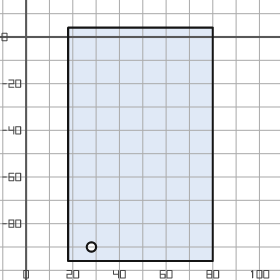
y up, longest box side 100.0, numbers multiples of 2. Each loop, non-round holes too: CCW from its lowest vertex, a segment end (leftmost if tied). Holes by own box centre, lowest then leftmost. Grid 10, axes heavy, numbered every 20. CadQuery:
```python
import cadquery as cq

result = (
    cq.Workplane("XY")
    .moveTo(18.0, -96.0)
    .lineTo(80.0, -96.0)
    .lineTo(80.0, 4.0)
    .lineTo(18.0, 4.0)
    .close()
    .moveTo(28.0, -90.0)
    .circle(2.0)
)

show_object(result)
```